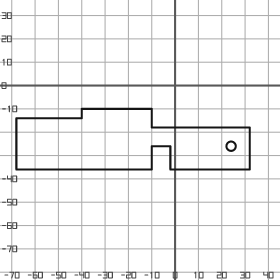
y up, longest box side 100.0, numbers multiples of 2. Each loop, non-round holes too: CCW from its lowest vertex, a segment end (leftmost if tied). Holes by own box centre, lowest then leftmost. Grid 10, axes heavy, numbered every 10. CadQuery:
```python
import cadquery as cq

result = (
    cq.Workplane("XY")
    .moveTo(-68.0, -36.0)
    .lineTo(-10.0, -36.0)
    .lineTo(-10.0, -26.0)
    .lineTo(-2.0, -26.0)
    .lineTo(-2.0, -36.0)
    .lineTo(32.0, -36.0)
    .lineTo(32.0, -18.0)
    .lineTo(-10.0, -18.0)
    .lineTo(-10.0, -10.0)
    .lineTo(-40.0, -10.0)
    .lineTo(-40.0, -14.0)
    .lineTo(-68.0, -14.0)
    .close()
    .moveTo(24.0, -26.0)
    .circle(2.0)
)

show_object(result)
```